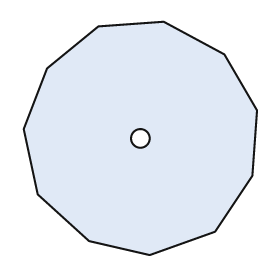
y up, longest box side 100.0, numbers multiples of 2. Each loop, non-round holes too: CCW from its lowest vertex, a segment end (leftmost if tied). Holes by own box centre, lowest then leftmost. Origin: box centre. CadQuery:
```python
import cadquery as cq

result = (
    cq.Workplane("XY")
    .moveTo(4.0, -50.0)
    .lineTo(32.0, -40.0)
    .lineTo(48.0, -16.0)
    .lineTo(50.0, 12.0)
    .lineTo(36.0, 36.0)
    .lineTo(10.0, 50.0)
    .lineTo(-18.0, 48.0)
    .lineTo(-40.0, 30.0)
    .lineTo(-50.0, 4.0)
    .lineTo(-44.0, -24.0)
    .lineTo(-22.0, -44.0)
    .close()
    .moveTo(0.0, 0.0)
    .circle(4.0)
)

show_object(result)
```